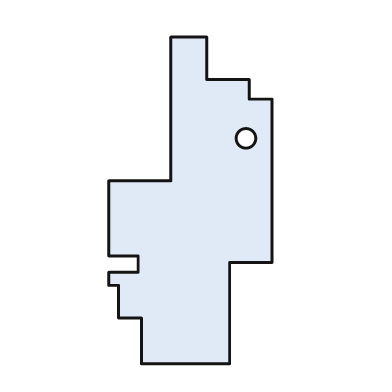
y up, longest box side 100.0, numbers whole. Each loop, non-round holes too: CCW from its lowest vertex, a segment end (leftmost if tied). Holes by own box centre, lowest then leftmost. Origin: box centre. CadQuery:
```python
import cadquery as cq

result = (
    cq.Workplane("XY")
    .moveTo(-15.0, -50.0)
    .lineTo(12.0, -50.0)
    .lineTo(12.0, -19.0)
    .lineTo(25.0, -19.0)
    .lineTo(25.0, 31.0)
    .lineTo(18.0, 31.0)
    .lineTo(18.0, 37.0)
    .lineTo(5.0, 37.0)
    .lineTo(5.0, 50.0)
    .lineTo(-6.0, 50.0)
    .lineTo(-6.0, 6.0)
    .lineTo(-25.0, 6.0)
    .lineTo(-25.0, -17.0)
    .lineTo(-16.0, -17.0)
    .lineTo(-16.0, -22.0)
    .lineTo(-25.0, -22.0)
    .lineTo(-25.0, -26.0)
    .lineTo(-22.0, -26.0)
    .lineTo(-22.0, -36.0)
    .lineTo(-15.0, -36.0)
    .close()
    .moveTo(17.0, 19.0)
    .circle(3.0)
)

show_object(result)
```